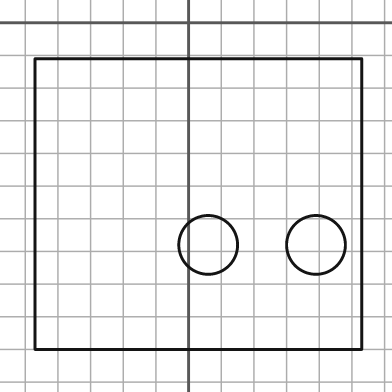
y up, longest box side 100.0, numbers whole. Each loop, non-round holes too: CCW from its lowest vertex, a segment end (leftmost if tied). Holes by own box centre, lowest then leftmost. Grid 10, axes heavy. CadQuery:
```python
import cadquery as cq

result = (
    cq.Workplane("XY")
    .moveTo(-47.0, -100.0)
    .lineTo(53.0, -100.0)
    .lineTo(53.0, -11.0)
    .lineTo(-47.0, -11.0)
    .close()
    .moveTo(6.0, -68.0)
    .circle(9.0)
    .moveTo(39.0, -68.0)
    .circle(9.0)
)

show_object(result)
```